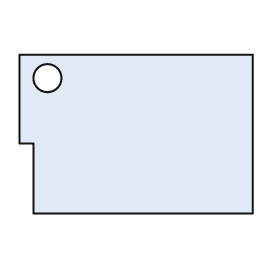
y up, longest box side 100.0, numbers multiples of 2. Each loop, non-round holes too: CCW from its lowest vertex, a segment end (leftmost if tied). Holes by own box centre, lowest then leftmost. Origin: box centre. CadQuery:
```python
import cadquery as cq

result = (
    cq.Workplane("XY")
    .moveTo(-44.0, -34.0)
    .lineTo(50.0, -34.0)
    .lineTo(50.0, 34.0)
    .lineTo(-50.0, 34.0)
    .lineTo(-50.0, -4.0)
    .lineTo(-44.0, -4.0)
    .close()
    .moveTo(-38.0, 24.0)
    .circle(6.0)
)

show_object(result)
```